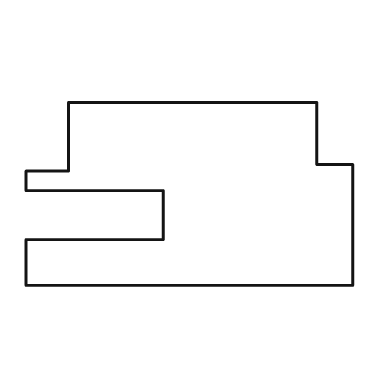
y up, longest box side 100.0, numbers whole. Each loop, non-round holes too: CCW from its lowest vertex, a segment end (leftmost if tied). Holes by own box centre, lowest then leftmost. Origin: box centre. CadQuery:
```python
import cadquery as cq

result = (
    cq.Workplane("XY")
    .moveTo(-50.0, -28.0)
    .lineTo(50.0, -28.0)
    .lineTo(50.0, 9.0)
    .lineTo(39.0, 9.0)
    .lineTo(39.0, 28.0)
    .lineTo(-37.0, 28.0)
    .lineTo(-37.0, 7.0)
    .lineTo(-50.0, 7.0)
    .lineTo(-50.0, 1.0)
    .lineTo(-8.0, 1.0)
    .lineTo(-8.0, -14.0)
    .lineTo(-50.0, -14.0)
    .close()
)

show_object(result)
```